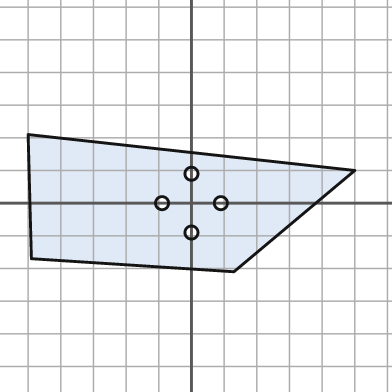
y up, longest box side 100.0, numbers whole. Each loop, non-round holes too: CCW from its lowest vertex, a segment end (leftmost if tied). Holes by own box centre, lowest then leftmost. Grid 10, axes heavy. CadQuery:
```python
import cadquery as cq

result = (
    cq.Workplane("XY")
    .moveTo(13.0, -21.0)
    .lineTo(50.0, 10.0)
    .lineTo(-50.0, 21.0)
    .lineTo(-49.0, -17.0)
    .close()
    .moveTo(0.0, -9.0)
    .circle(2.0)
    .moveTo(-9.0, 0.0)
    .circle(2.0)
    .moveTo(9.0, 0.0)
    .circle(2.0)
    .moveTo(0.0, 9.0)
    .circle(2.0)
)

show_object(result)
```